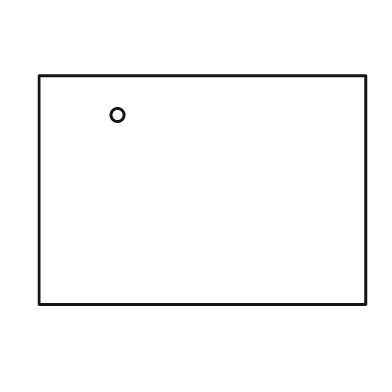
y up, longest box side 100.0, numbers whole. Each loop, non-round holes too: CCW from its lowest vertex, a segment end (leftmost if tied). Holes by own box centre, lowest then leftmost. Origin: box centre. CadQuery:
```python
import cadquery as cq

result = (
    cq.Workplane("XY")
    .moveTo(-50.0, -35.0)
    .lineTo(50.0, -35.0)
    .lineTo(50.0, 35.0)
    .lineTo(-50.0, 35.0)
    .close()
    .moveTo(-26.0, 23.0)
    .circle(2.0)
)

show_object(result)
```